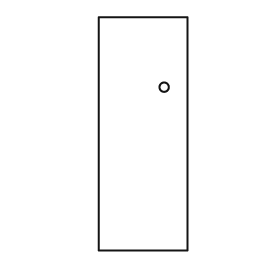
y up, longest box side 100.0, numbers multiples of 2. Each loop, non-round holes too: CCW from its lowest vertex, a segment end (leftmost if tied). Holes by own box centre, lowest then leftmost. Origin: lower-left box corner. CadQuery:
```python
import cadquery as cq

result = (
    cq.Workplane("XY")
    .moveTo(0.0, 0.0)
    .lineTo(38.0, 0.0)
    .lineTo(38.0, 100.0)
    .lineTo(0.0, 100.0)
    .close()
    .moveTo(28.0, 70.0)
    .circle(2.0)
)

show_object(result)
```